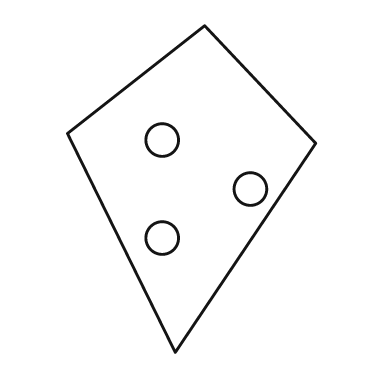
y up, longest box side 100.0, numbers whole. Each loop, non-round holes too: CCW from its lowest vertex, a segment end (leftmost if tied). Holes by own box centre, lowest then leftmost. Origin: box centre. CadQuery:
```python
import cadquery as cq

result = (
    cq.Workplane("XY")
    .moveTo(-5.0, -50.0)
    .lineTo(38.0, 14.0)
    .lineTo(4.0, 50.0)
    .lineTo(-38.0, 17.0)
    .close()
    .moveTo(-9.0, -15.0)
    .circle(5.0)
    .moveTo(18.0, 0.0)
    .circle(5.0)
    .moveTo(-9.0, 15.0)
    .circle(5.0)
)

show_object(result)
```